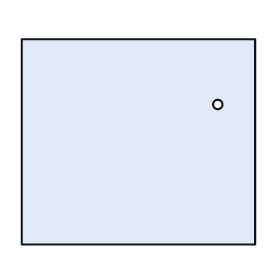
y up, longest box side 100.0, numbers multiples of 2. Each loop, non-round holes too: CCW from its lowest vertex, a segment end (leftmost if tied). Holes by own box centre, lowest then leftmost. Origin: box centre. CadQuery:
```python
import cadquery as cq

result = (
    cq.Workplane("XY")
    .moveTo(-50.0, -44.0)
    .lineTo(50.0, -44.0)
    .lineTo(50.0, 44.0)
    .lineTo(-50.0, 44.0)
    .close()
    .moveTo(34.0, 16.0)
    .circle(2.0)
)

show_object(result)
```